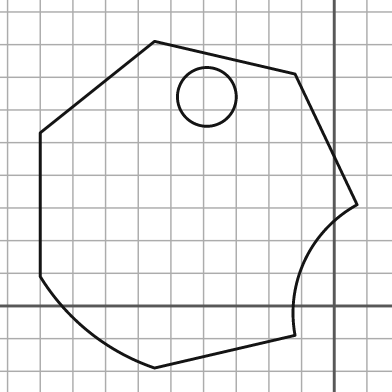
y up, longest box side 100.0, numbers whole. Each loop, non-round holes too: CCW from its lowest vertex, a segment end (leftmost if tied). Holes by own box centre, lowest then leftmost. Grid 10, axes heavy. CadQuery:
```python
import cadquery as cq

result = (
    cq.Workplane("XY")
    .moveTo(-55.0, -19.0)
    .lineTo(-12.0, -9.0)
    .threePointArc((-9.0, 14.0), (7.0, 31.0))
    .lineTo(-12.0, 71.0)
    .lineTo(-55.0, 81.0)
    .lineTo(-90.0, 53.0)
    .lineTo(-90.0, 9.0)
    .threePointArc((-75.0, -8.0), (-55.0, -19.0))
    .close()
    .moveTo(-39.0, 64.0)
    .circle(9.0)
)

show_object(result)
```